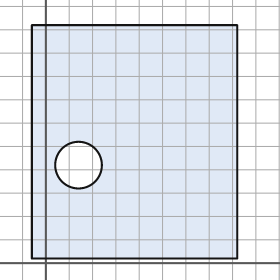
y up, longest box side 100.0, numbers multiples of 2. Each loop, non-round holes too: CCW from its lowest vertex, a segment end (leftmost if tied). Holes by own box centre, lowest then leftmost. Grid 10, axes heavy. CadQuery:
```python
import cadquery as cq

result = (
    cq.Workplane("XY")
    .moveTo(-6.0, 2.0)
    .lineTo(82.0, 2.0)
    .lineTo(82.0, 102.0)
    .lineTo(-6.0, 102.0)
    .close()
    .moveTo(14.0, 42.0)
    .circle(10.0)
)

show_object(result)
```